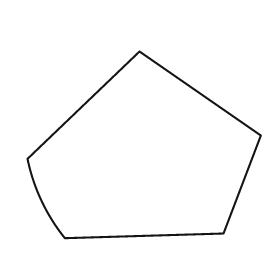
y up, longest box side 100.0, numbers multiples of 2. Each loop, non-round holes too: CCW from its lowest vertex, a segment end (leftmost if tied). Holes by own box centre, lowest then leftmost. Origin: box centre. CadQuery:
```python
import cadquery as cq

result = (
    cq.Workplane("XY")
    .moveTo(-34.0, -40.0)
    .lineTo(34.0, -38.0)
    .lineTo(50.0, 4.0)
    .lineTo(-2.0, 40.0)
    .lineTo(-50.0, -6.0)
    .threePointArc((-44.0, -24.0), (-34.0, -40.0))
    .close()
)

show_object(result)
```